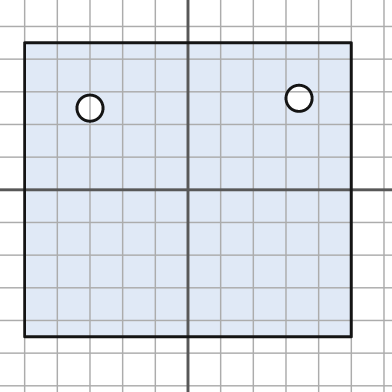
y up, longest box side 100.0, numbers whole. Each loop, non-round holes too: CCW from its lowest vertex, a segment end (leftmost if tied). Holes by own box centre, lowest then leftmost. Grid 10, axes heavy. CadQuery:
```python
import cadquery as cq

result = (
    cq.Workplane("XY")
    .moveTo(-50.0, -45.0)
    .lineTo(50.0, -45.0)
    .lineTo(50.0, 45.0)
    .lineTo(-50.0, 45.0)
    .close()
    .moveTo(-30.0, 25.0)
    .circle(4.0)
    .moveTo(34.0, 28.0)
    .circle(4.0)
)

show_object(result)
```